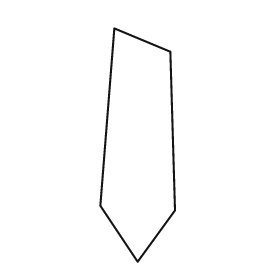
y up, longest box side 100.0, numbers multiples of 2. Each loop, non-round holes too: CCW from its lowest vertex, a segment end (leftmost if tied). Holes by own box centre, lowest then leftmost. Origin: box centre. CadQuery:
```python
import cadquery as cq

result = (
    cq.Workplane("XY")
    .moveTo(0.0, -50.0)
    .lineTo(16.0, -28.0)
    .lineTo(14.0, 40.0)
    .lineTo(-10.0, 50.0)
    .lineTo(-16.0, -26.0)
    .close()
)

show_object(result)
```